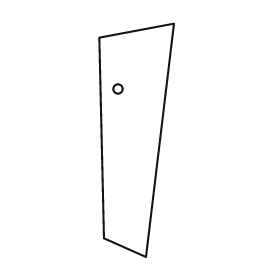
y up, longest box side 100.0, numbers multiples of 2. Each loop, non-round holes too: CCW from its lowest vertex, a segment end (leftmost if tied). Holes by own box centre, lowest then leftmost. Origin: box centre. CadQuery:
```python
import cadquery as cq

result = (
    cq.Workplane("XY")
    .moveTo(4.0, -50.0)
    .lineTo(16.0, 50.0)
    .lineTo(-16.0, 44.0)
    .lineTo(-14.0, -42.0)
    .close()
    .moveTo(-8.0, 22.0)
    .circle(2.0)
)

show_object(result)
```